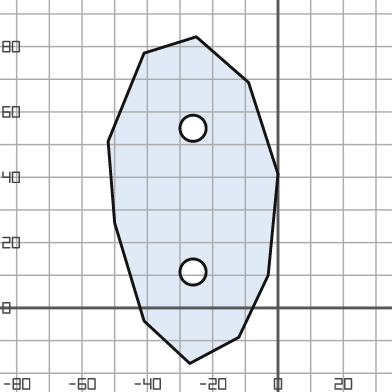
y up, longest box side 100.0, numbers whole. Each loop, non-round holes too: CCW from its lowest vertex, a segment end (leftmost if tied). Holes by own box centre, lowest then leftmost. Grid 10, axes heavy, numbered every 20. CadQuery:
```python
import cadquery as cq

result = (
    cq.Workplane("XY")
    .moveTo(-27.0, -17.0)
    .lineTo(-12.0, -9.0)
    .lineTo(-3.0, 10.0)
    .lineTo(0.0, 41.0)
    .lineTo(-9.0, 69.0)
    .lineTo(-25.0, 83.0)
    .lineTo(-41.0, 78.0)
    .lineTo(-52.0, 51.0)
    .lineTo(-50.0, 26.0)
    .lineTo(-41.0, -4.0)
    .close()
    .moveTo(-26.0, 11.0)
    .circle(4.0)
    .moveTo(-26.0, 55.0)
    .circle(4.0)
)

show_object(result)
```